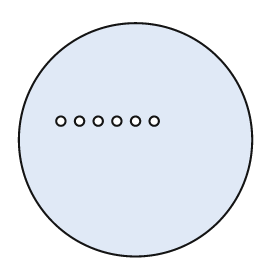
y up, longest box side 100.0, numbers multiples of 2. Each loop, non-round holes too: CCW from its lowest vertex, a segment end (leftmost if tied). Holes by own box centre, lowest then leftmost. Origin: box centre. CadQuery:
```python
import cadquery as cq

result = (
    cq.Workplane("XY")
    .moveTo(0.0, 0.0)
    .circle(50.0)
    .moveTo(-32.0, 8.0)
    .circle(2.0)
    .moveTo(-24.0, 8.0)
    .circle(2.0)
    .moveTo(-16.0, 8.0)
    .circle(2.0)
    .moveTo(-8.0, 8.0)
    .circle(2.0)
    .moveTo(0.0, 8.0)
    .circle(2.0)
    .moveTo(8.0, 8.0)
    .circle(2.0)
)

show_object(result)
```